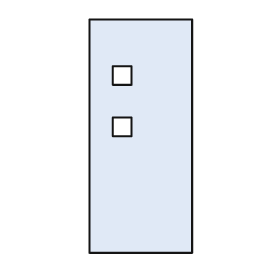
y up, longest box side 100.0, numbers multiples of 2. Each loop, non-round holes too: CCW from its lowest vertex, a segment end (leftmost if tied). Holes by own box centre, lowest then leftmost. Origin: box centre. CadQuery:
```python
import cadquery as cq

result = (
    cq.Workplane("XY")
    .moveTo(-22.0, -50.0)
    .lineTo(22.0, -50.0)
    .lineTo(22.0, 50.0)
    .lineTo(-22.0, 50.0)
    .close()
    .moveTo(-12.0, 0.0)
    .lineTo(-4.0, 0.0)
    .lineTo(-4.0, 8.0)
    .lineTo(-12.0, 8.0)
    .close()
    .moveTo(-12.0, 22.0)
    .lineTo(-4.0, 22.0)
    .lineTo(-4.0, 30.0)
    .lineTo(-12.0, 30.0)
    .close()
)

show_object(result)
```